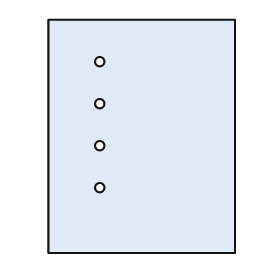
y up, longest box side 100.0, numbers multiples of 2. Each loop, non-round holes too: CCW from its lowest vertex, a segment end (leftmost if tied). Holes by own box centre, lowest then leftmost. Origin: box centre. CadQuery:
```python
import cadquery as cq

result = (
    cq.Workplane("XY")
    .moveTo(-40.0, -50.0)
    .lineTo(40.0, -50.0)
    .lineTo(40.0, 50.0)
    .lineTo(-40.0, 50.0)
    .close()
    .moveTo(-18.0, -22.0)
    .circle(2.0)
    .moveTo(-18.0, -4.0)
    .circle(2.0)
    .moveTo(-18.0, 14.0)
    .circle(2.0)
    .moveTo(-18.0, 32.0)
    .circle(2.0)
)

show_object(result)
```